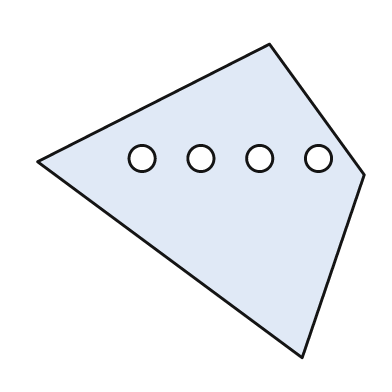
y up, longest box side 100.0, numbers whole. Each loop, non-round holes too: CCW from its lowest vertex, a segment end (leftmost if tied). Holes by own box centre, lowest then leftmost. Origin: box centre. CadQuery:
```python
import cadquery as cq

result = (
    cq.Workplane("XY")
    .moveTo(31.0, -48.0)
    .lineTo(50.0, 8.0)
    .lineTo(21.0, 48.0)
    .lineTo(-50.0, 12.0)
    .close()
    .moveTo(-18.0, 13.0)
    .circle(4.0)
    .moveTo(0.0, 13.0)
    .circle(4.0)
    .moveTo(18.0, 13.0)
    .circle(4.0)
    .moveTo(36.0, 13.0)
    .circle(4.0)
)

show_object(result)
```